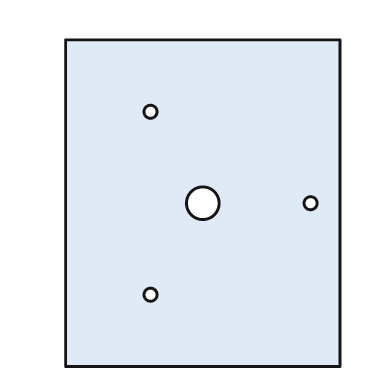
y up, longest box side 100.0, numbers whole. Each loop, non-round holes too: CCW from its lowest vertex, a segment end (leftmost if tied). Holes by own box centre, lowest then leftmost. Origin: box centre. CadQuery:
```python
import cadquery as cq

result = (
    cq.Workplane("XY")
    .moveTo(-42.0, -50.0)
    .lineTo(42.0, -50.0)
    .lineTo(42.0, 50.0)
    .lineTo(-42.0, 50.0)
    .close()
    .moveTo(-16.0, -28.0)
    .circle(2.0)
    .moveTo(0.0, 0.0)
    .circle(5.0)
    .moveTo(33.0, 0.0)
    .circle(2.0)
    .moveTo(-16.0, 28.0)
    .circle(2.0)
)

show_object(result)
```